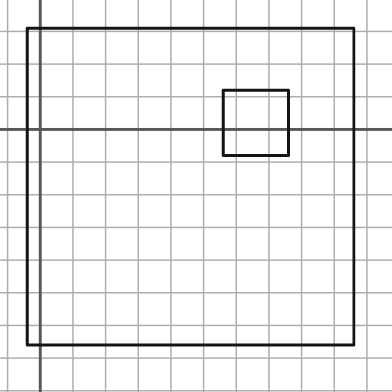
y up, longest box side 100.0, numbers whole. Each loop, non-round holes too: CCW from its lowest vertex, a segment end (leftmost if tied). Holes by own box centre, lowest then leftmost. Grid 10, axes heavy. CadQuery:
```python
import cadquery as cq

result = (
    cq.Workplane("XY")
    .moveTo(-4.0, -66.0)
    .lineTo(96.0, -66.0)
    .lineTo(96.0, 31.0)
    .lineTo(-4.0, 31.0)
    .close()
    .moveTo(56.0, -8.0)
    .lineTo(76.0, -8.0)
    .lineTo(76.0, 12.0)
    .lineTo(56.0, 12.0)
    .close()
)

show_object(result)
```